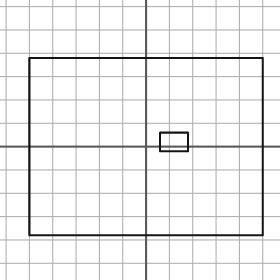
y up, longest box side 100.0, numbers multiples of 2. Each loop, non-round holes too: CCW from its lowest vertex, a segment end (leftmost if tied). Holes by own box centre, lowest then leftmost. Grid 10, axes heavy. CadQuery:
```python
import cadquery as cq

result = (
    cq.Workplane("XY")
    .moveTo(-50.0, -38.0)
    .lineTo(50.0, -38.0)
    .lineTo(50.0, 38.0)
    .lineTo(-50.0, 38.0)
    .close()
    .moveTo(6.0, -2.0)
    .lineTo(18.0, -2.0)
    .lineTo(18.0, 6.0)
    .lineTo(6.0, 6.0)
    .close()
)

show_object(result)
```